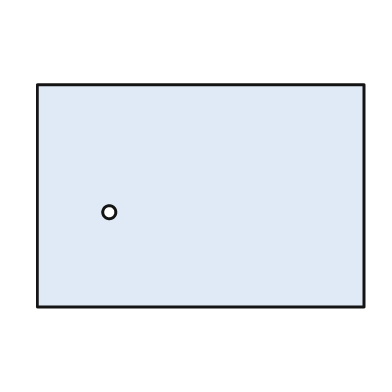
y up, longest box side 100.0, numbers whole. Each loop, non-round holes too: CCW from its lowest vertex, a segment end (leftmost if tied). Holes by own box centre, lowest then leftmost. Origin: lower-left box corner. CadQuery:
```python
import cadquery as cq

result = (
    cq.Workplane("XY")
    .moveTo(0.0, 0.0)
    .lineTo(100.0, 0.0)
    .lineTo(100.0, 68.0)
    .lineTo(0.0, 68.0)
    .close()
    .moveTo(22.0, 29.0)
    .circle(2.0)
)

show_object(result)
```